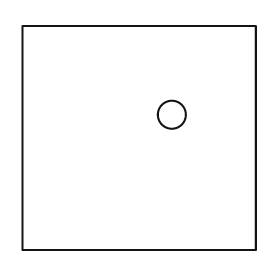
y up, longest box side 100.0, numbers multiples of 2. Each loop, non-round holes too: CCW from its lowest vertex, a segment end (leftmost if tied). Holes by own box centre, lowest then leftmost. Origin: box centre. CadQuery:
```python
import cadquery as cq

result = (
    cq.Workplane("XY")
    .moveTo(-50.0, -48.0)
    .lineTo(50.0, -48.0)
    .lineTo(50.0, 48.0)
    .lineTo(-50.0, 48.0)
    .close()
    .moveTo(14.0, 10.0)
    .circle(6.0)
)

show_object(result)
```